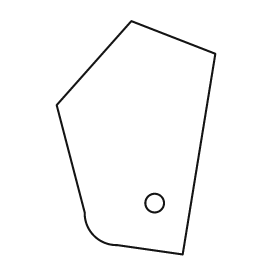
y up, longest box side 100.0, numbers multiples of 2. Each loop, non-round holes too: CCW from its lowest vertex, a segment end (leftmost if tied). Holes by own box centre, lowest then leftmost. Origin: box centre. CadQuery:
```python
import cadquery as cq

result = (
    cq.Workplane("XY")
    .moveTo(20.0, -50.0)
    .lineTo(34.0, 36.0)
    .lineTo(-2.0, 50.0)
    .lineTo(-34.0, 14.0)
    .lineTo(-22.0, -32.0)
    .threePointArc((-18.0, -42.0), (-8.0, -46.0))
    .close()
    .moveTo(8.0, -28.0)
    .circle(4.0)
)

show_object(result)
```